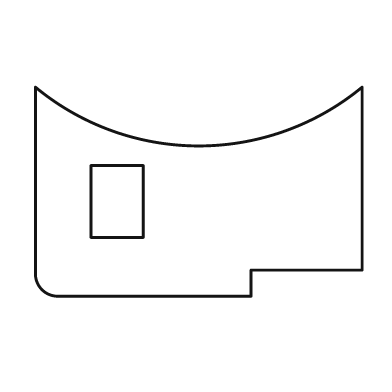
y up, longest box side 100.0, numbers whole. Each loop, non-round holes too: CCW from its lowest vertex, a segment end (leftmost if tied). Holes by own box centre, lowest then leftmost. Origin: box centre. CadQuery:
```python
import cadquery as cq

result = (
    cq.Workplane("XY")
    .moveTo(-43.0, -32.0)
    .lineTo(16.0, -32.0)
    .lineTo(16.0, -24.0)
    .lineTo(50.0, -24.0)
    .lineTo(50.0, 32.0)
    .threePointArc((0.0, 14.0), (-50.0, 32.0))
    .lineTo(-50.0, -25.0)
    .threePointArc((-48.0, -30.0), (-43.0, -32.0))
    .close()
    .moveTo(-33.0, -14.0)
    .lineTo(-17.0, -14.0)
    .lineTo(-17.0, 8.0)
    .lineTo(-33.0, 8.0)
    .close()
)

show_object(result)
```